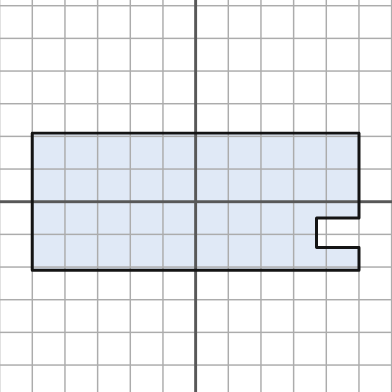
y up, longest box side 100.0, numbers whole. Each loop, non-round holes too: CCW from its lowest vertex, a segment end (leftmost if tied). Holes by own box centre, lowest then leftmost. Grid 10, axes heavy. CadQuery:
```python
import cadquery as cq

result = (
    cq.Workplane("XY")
    .moveTo(-50.0, -21.0)
    .lineTo(50.0, -21.0)
    .lineTo(50.0, -14.0)
    .lineTo(37.0, -14.0)
    .lineTo(37.0, -5.0)
    .lineTo(50.0, -5.0)
    .lineTo(50.0, 21.0)
    .lineTo(-50.0, 21.0)
    .close()
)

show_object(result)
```